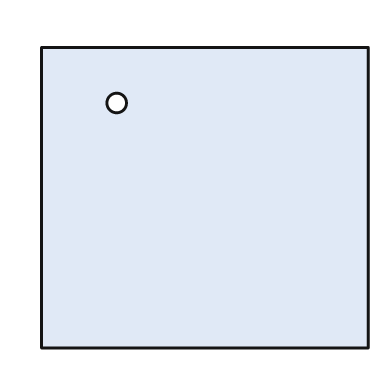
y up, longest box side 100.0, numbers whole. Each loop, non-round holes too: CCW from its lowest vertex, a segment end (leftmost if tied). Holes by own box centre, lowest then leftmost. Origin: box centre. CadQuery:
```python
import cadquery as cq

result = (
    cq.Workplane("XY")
    .moveTo(-50.0, -46.0)
    .lineTo(50.0, -46.0)
    .lineTo(50.0, 46.0)
    .lineTo(-50.0, 46.0)
    .close()
    .moveTo(-27.0, 29.0)
    .circle(3.0)
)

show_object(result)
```